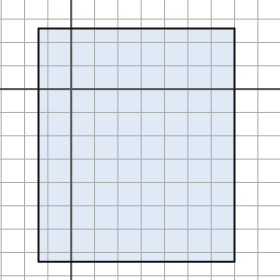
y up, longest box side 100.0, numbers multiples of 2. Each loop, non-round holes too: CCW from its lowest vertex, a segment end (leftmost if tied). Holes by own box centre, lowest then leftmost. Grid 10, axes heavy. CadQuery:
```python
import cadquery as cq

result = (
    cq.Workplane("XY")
    .moveTo(-14.0, -74.0)
    .lineTo(70.0, -74.0)
    .lineTo(70.0, 26.0)
    .lineTo(-14.0, 26.0)
    .close()
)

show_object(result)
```